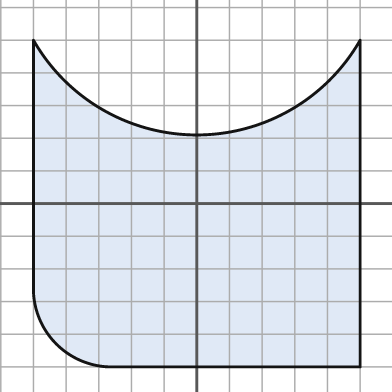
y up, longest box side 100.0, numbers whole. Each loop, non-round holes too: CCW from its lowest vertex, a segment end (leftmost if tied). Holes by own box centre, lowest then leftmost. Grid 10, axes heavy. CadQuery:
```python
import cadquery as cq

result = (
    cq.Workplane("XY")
    .moveTo(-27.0, -50.0)
    .lineTo(50.0, -50.0)
    .lineTo(50.0, 50.0)
    .threePointArc((0.0, 21.0), (-50.0, 50.0))
    .lineTo(-50.0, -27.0)
    .threePointArc((-43.0, -43.0), (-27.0, -50.0))
    .close()
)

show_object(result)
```